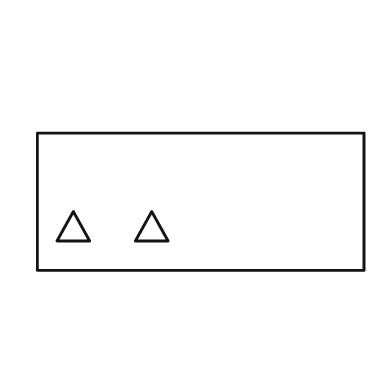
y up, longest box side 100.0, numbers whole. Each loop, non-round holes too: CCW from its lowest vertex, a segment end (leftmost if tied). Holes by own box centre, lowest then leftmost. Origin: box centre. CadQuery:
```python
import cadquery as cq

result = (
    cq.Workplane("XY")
    .moveTo(-50.0, -21.0)
    .lineTo(50.0, -21.0)
    .lineTo(50.0, 21.0)
    .lineTo(-50.0, 21.0)
    .close()
    .moveTo(-44.0, -12.0)
    .lineTo(-34.0, -12.0)
    .lineTo(-39.0, -3.0)
    .close()
    .moveTo(-20.0, -12.0)
    .lineTo(-10.0, -12.0)
    .lineTo(-15.0, -3.0)
    .close()
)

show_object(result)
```